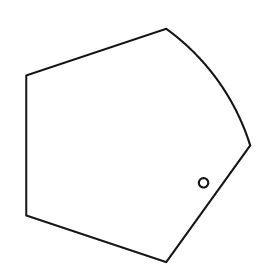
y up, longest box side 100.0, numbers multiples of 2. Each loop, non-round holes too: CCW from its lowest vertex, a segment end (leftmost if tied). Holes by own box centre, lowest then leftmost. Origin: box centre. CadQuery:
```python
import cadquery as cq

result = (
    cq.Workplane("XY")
    .moveTo(12.0, -50.0)
    .lineTo(48.0, 0.0)
    .threePointArc((34.0, 28.0), (12.0, 50.0))
    .lineTo(-48.0, 30.0)
    .lineTo(-48.0, -30.0)
    .close()
    .moveTo(28.0, -16.0)
    .circle(2.0)
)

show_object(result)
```